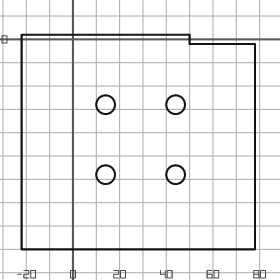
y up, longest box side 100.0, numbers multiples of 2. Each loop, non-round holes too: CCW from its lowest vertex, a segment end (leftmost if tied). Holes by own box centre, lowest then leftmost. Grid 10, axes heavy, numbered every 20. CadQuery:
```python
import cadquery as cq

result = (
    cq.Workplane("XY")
    .moveTo(-22.0, -90.0)
    .lineTo(78.0, -90.0)
    .lineTo(78.0, -2.0)
    .lineTo(50.0, -2.0)
    .lineTo(50.0, 2.0)
    .lineTo(-22.0, 2.0)
    .close()
    .moveTo(14.0, -58.0)
    .circle(4.0)
    .moveTo(44.0, -58.0)
    .circle(4.0)
    .moveTo(14.0, -28.0)
    .circle(4.0)
    .moveTo(44.0, -28.0)
    .circle(4.0)
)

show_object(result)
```